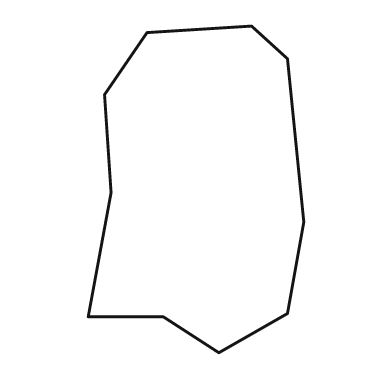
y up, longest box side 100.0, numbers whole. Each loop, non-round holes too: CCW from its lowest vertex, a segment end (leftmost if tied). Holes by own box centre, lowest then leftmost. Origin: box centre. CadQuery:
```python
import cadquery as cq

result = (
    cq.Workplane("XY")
    .moveTo(7.0, -50.0)
    .lineTo(28.0, -38.0)
    .lineTo(33.0, -10.0)
    .lineTo(28.0, 40.0)
    .lineTo(17.0, 50.0)
    .lineTo(-15.0, 48.0)
    .lineTo(-28.0, 29.0)
    .lineTo(-26.0, -1.0)
    .lineTo(-33.0, -39.0)
    .lineTo(-10.0, -39.0)
    .close()
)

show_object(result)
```